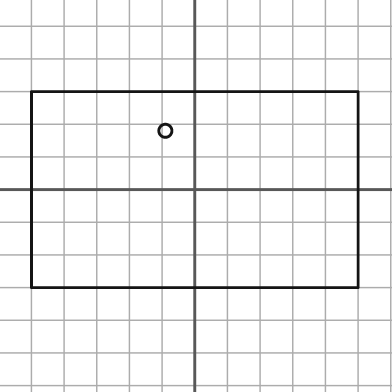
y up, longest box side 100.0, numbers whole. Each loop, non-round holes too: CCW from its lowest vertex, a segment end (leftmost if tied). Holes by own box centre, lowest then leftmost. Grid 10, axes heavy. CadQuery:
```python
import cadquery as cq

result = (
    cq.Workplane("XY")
    .moveTo(-50.0, -30.0)
    .lineTo(50.0, -30.0)
    .lineTo(50.0, 30.0)
    .lineTo(-50.0, 30.0)
    .close()
    .moveTo(-9.0, 18.0)
    .circle(2.0)
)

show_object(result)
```